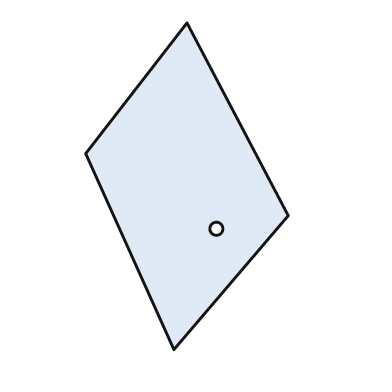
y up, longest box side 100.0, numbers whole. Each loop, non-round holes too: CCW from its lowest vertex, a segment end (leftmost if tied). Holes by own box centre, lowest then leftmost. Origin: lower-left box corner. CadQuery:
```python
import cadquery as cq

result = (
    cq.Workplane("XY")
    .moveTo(27.0, 0.0)
    .lineTo(62.0, 41.0)
    .lineTo(31.0, 100.0)
    .lineTo(0.0, 60.0)
    .close()
    .moveTo(40.0, 37.0)
    .circle(2.0)
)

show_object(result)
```